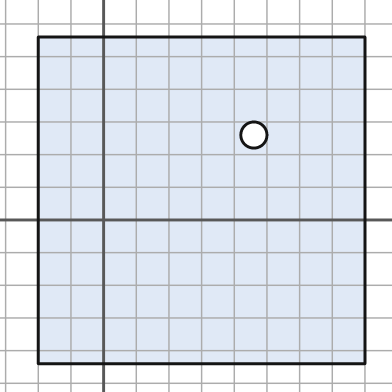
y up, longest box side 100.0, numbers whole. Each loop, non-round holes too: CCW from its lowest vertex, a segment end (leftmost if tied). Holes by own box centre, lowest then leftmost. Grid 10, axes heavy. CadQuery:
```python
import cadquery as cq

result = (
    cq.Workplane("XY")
    .moveTo(-20.0, -44.0)
    .lineTo(80.0, -44.0)
    .lineTo(80.0, 56.0)
    .lineTo(-20.0, 56.0)
    .close()
    .moveTo(46.0, 26.0)
    .circle(4.0)
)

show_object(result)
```